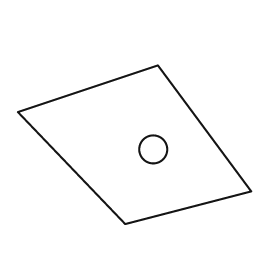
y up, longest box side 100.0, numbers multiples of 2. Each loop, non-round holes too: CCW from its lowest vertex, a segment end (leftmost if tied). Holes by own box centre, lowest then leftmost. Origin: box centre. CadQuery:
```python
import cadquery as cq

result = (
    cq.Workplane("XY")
    .moveTo(-4.0, -34.0)
    .lineTo(50.0, -20.0)
    .lineTo(10.0, 34.0)
    .lineTo(-50.0, 14.0)
    .close()
    .moveTo(8.0, -2.0)
    .circle(6.0)
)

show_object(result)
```